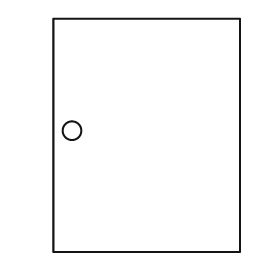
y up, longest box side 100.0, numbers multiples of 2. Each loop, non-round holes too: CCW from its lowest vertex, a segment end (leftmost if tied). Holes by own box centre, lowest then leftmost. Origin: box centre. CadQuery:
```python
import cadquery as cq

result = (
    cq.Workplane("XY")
    .moveTo(-40.0, -50.0)
    .lineTo(40.0, -50.0)
    .lineTo(40.0, 50.0)
    .lineTo(-40.0, 50.0)
    .close()
    .moveTo(-32.0, 2.0)
    .circle(4.0)
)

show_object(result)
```